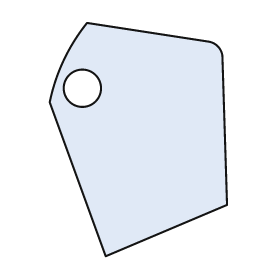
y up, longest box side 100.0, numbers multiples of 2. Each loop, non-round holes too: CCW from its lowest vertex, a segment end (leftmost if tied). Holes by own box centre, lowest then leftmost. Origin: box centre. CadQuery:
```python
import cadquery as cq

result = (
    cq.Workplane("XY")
    .moveTo(-14.0, -50.0)
    .lineTo(38.0, -28.0)
    .lineTo(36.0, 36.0)
    .threePointArc((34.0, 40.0), (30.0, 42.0))
    .lineTo(-22.0, 50.0)
    .threePointArc((-32.0, 34.0), (-38.0, 16.0))
    .close()
    .moveTo(-24.0, 22.0)
    .circle(8.0)
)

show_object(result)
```